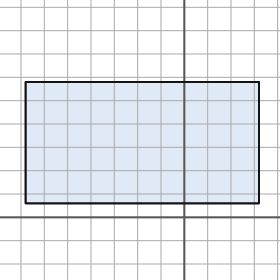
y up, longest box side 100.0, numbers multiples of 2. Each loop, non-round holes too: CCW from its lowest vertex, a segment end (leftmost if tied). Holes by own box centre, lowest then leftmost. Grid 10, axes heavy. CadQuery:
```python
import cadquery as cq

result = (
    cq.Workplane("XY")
    .moveTo(-68.0, 6.0)
    .lineTo(32.0, 6.0)
    .lineTo(32.0, 58.0)
    .lineTo(-68.0, 58.0)
    .close()
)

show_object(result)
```